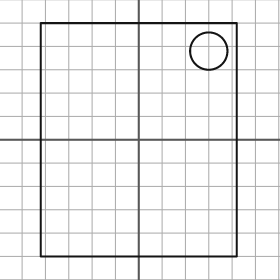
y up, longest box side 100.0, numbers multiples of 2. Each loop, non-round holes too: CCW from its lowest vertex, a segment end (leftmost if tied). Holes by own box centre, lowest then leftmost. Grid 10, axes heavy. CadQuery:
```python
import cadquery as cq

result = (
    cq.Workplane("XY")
    .moveTo(-42.0, -50.0)
    .lineTo(42.0, -50.0)
    .lineTo(42.0, 50.0)
    .lineTo(-42.0, 50.0)
    .close()
    .moveTo(30.0, 38.0)
    .circle(8.0)
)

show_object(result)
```